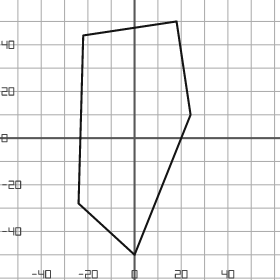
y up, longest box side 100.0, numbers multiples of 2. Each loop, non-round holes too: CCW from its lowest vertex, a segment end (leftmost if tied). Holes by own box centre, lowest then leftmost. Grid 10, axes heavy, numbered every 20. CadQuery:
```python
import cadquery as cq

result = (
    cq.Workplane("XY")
    .moveTo(0.0, -50.0)
    .lineTo(24.0, 10.0)
    .lineTo(18.0, 50.0)
    .lineTo(-22.0, 44.0)
    .lineTo(-24.0, -28.0)
    .close()
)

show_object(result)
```